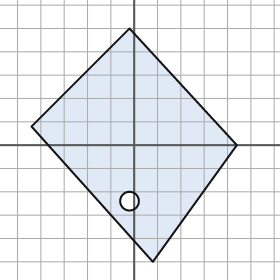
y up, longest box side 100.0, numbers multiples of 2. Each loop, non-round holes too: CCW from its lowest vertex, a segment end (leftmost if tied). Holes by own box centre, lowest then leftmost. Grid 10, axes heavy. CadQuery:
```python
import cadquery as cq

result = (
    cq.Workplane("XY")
    .moveTo(8.0, -50.0)
    .lineTo(44.0, 0.0)
    .lineTo(-2.0, 50.0)
    .lineTo(-44.0, 8.0)
    .close()
    .moveTo(-2.0, -24.0)
    .circle(4.0)
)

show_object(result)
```